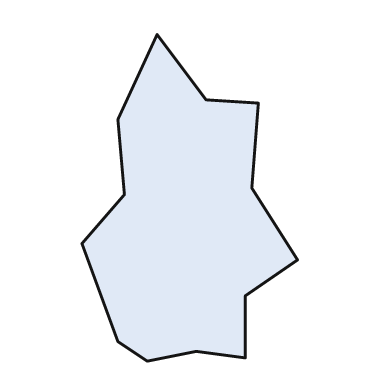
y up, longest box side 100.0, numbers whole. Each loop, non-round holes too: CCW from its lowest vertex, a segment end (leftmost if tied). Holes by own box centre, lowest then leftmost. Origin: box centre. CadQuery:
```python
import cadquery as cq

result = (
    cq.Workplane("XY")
    .moveTo(-13.0, -50.0)
    .lineTo(2.0, -47.0)
    .lineTo(17.0, -49.0)
    .lineTo(17.0, -30.0)
    .lineTo(33.0, -19.0)
    .lineTo(19.0, 3.0)
    .lineTo(21.0, 29.0)
    .lineTo(5.0, 30.0)
    .lineTo(-10.0, 50.0)
    .lineTo(-22.0, 24.0)
    .lineTo(-20.0, 1.0)
    .lineTo(-33.0, -14.0)
    .lineTo(-22.0, -44.0)
    .close()
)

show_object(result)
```